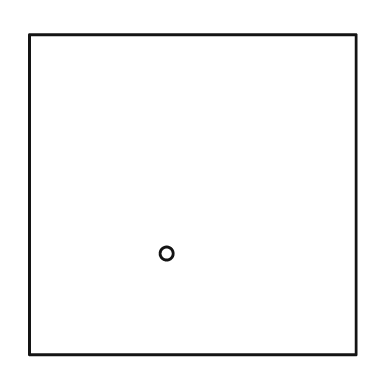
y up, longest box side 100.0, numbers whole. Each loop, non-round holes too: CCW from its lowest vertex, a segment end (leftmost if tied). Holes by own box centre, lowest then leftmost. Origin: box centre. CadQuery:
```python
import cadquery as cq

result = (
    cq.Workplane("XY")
    .moveTo(-50.0, -49.0)
    .lineTo(50.0, -49.0)
    .lineTo(50.0, 49.0)
    .lineTo(-50.0, 49.0)
    .close()
    .moveTo(-8.0, -18.0)
    .circle(2.0)
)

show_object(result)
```